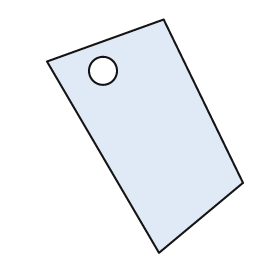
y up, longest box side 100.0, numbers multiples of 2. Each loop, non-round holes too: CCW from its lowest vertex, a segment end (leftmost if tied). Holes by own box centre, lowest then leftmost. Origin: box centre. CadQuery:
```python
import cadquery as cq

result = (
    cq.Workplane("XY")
    .moveTo(6.0, -50.0)
    .lineTo(42.0, -20.0)
    .lineTo(8.0, 50.0)
    .lineTo(-42.0, 32.0)
    .close()
    .moveTo(-18.0, 28.0)
    .circle(6.0)
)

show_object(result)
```